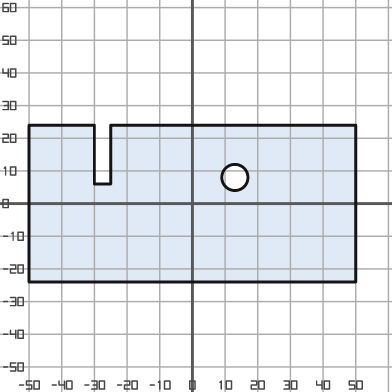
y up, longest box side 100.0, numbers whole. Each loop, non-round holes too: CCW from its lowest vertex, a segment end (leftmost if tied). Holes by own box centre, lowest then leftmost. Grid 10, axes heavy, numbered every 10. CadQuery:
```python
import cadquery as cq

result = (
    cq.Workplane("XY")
    .moveTo(-50.0, -24.0)
    .lineTo(50.0, -24.0)
    .lineTo(50.0, 24.0)
    .lineTo(-25.0, 24.0)
    .lineTo(-25.0, 6.0)
    .lineTo(-30.0, 6.0)
    .lineTo(-30.0, 24.0)
    .lineTo(-50.0, 24.0)
    .close()
    .moveTo(13.0, 8.0)
    .circle(4.0)
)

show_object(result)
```